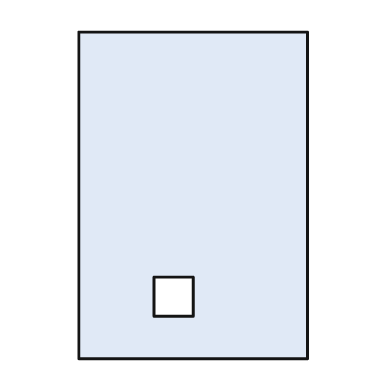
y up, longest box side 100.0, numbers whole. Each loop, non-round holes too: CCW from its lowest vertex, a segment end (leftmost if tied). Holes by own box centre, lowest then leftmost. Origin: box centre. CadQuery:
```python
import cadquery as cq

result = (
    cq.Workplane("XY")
    .moveTo(-35.0, -50.0)
    .lineTo(35.0, -50.0)
    .lineTo(35.0, 50.0)
    .lineTo(-35.0, 50.0)
    .close()
    .moveTo(-12.0, -37.0)
    .lineTo(0.0, -37.0)
    .lineTo(0.0, -25.0)
    .lineTo(-12.0, -25.0)
    .close()
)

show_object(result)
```